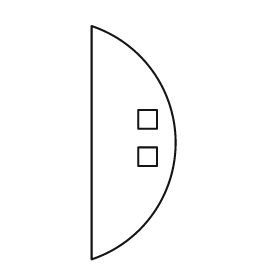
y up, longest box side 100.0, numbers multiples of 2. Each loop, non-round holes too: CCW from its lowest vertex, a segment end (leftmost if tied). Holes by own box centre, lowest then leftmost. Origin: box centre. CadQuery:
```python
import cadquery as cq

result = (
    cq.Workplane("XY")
    .moveTo(-18.0, -50.0)
    .threePointArc((18.0, 0.0), (-18.0, 50.0))
    .close()
    .moveTo(2.0, -10.0)
    .lineTo(10.0, -10.0)
    .lineTo(10.0, -2.0)
    .lineTo(2.0, -2.0)
    .close()
    .moveTo(2.0, 6.0)
    .lineTo(10.0, 6.0)
    .lineTo(10.0, 14.0)
    .lineTo(2.0, 14.0)
    .close()
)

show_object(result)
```